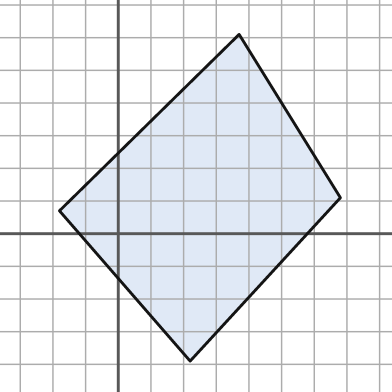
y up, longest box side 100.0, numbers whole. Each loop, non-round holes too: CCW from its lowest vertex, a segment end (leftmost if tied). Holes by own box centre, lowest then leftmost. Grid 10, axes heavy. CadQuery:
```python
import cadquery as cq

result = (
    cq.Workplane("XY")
    .moveTo(22.0, -39.0)
    .lineTo(68.0, 11.0)
    .lineTo(37.0, 61.0)
    .lineTo(-18.0, 7.0)
    .close()
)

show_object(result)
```